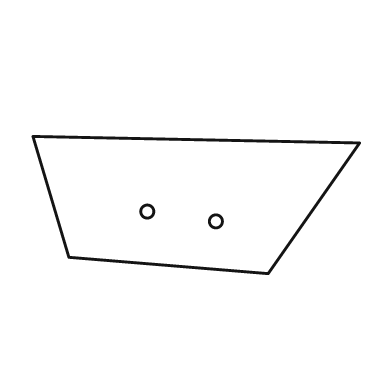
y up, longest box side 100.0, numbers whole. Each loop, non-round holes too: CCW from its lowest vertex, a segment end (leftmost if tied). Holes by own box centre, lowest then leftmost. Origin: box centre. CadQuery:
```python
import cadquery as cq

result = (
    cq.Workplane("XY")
    .moveTo(22.0, -21.0)
    .lineTo(50.0, 19.0)
    .lineTo(-50.0, 21.0)
    .lineTo(-39.0, -16.0)
    .close()
    .moveTo(6.0, -5.0)
    .circle(2.0)
    .moveTo(-15.0, -2.0)
    .circle(2.0)
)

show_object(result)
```